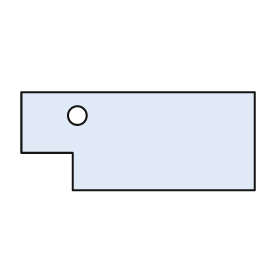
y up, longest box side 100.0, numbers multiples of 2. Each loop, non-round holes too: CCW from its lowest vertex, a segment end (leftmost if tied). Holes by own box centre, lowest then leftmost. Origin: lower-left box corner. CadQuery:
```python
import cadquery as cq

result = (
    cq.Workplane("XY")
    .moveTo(22.0, 0.0)
    .lineTo(100.0, 0.0)
    .lineTo(100.0, 42.0)
    .lineTo(0.0, 42.0)
    .lineTo(0.0, 16.0)
    .lineTo(22.0, 16.0)
    .close()
    .moveTo(24.0, 32.0)
    .circle(4.0)
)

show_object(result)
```